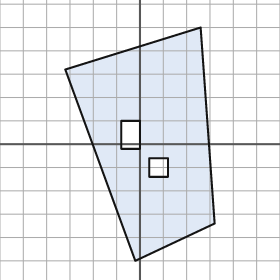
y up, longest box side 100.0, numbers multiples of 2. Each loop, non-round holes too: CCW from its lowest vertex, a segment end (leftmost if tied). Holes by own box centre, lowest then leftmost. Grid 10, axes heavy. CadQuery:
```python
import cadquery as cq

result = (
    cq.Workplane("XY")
    .moveTo(-2.0, -50.0)
    .lineTo(32.0, -34.0)
    .lineTo(26.0, 50.0)
    .lineTo(-32.0, 32.0)
    .close()
    .moveTo(4.0, -14.0)
    .lineTo(12.0, -14.0)
    .lineTo(12.0, -6.0)
    .lineTo(4.0, -6.0)
    .close()
    .moveTo(-8.0, -2.0)
    .lineTo(0.0, -2.0)
    .lineTo(0.0, 10.0)
    .lineTo(-8.0, 10.0)
    .close()
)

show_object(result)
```